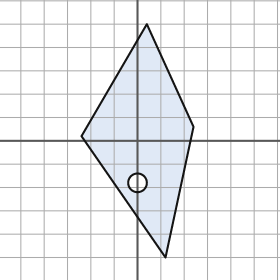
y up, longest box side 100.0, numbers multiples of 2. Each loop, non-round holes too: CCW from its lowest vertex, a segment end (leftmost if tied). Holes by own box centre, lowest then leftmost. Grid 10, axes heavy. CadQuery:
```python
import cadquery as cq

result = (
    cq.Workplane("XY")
    .moveTo(12.0, -50.0)
    .lineTo(24.0, 6.0)
    .lineTo(4.0, 50.0)
    .lineTo(-24.0, 2.0)
    .close()
    .moveTo(0.0, -18.0)
    .circle(4.0)
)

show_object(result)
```